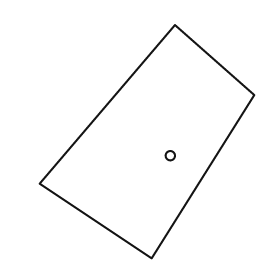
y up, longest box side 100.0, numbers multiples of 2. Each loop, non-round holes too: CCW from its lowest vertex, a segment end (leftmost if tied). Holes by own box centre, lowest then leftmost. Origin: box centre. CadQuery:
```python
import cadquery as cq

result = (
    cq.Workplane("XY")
    .moveTo(2.0, -50.0)
    .lineTo(46.0, 20.0)
    .lineTo(12.0, 50.0)
    .lineTo(-46.0, -18.0)
    .close()
    .moveTo(10.0, -6.0)
    .circle(2.0)
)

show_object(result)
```